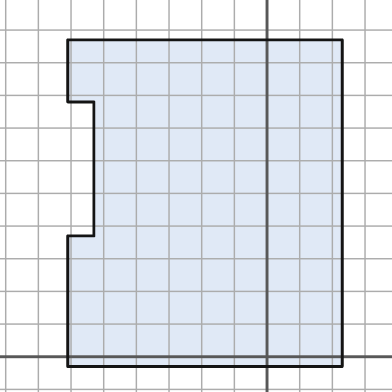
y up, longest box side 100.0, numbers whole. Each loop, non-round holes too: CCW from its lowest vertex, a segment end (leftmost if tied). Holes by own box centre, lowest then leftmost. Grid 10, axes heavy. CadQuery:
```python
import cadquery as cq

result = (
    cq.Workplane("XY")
    .moveTo(-61.0, -3.0)
    .lineTo(23.0, -3.0)
    .lineTo(23.0, 97.0)
    .lineTo(-61.0, 97.0)
    .lineTo(-61.0, 78.0)
    .lineTo(-53.0, 78.0)
    .lineTo(-53.0, 37.0)
    .lineTo(-61.0, 37.0)
    .close()
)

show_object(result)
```